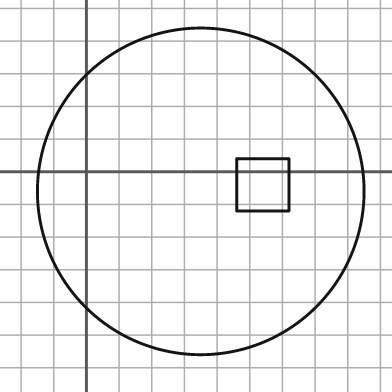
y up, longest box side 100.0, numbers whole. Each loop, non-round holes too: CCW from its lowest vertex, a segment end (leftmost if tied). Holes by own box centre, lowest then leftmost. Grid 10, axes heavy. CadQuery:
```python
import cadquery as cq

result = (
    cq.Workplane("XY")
    .moveTo(35.0, -6.0)
    .circle(50.0)
    .moveTo(46.0, -12.0)
    .lineTo(62.0, -12.0)
    .lineTo(62.0, 4.0)
    .lineTo(46.0, 4.0)
    .close()
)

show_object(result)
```